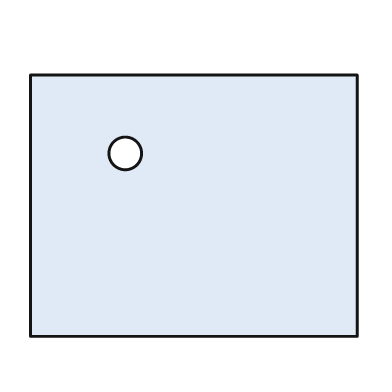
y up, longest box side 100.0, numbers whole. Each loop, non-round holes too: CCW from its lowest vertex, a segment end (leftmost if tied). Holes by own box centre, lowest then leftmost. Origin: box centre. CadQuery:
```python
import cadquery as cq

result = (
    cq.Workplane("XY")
    .moveTo(-50.0, -40.0)
    .lineTo(50.0, -40.0)
    .lineTo(50.0, 40.0)
    .lineTo(-50.0, 40.0)
    .close()
    .moveTo(-21.0, 16.0)
    .circle(5.0)
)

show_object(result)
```